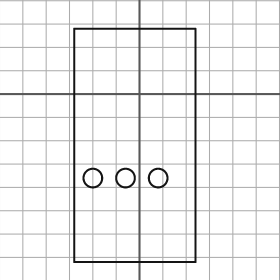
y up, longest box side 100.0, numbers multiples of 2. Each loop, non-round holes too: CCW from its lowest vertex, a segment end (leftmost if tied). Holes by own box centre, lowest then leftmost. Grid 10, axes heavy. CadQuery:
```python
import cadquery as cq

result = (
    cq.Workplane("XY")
    .moveTo(-28.0, -72.0)
    .lineTo(24.0, -72.0)
    .lineTo(24.0, 28.0)
    .lineTo(-28.0, 28.0)
    .close()
    .moveTo(-20.0, -36.0)
    .circle(4.0)
    .moveTo(-6.0, -36.0)
    .circle(4.0)
    .moveTo(8.0, -36.0)
    .circle(4.0)
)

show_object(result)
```